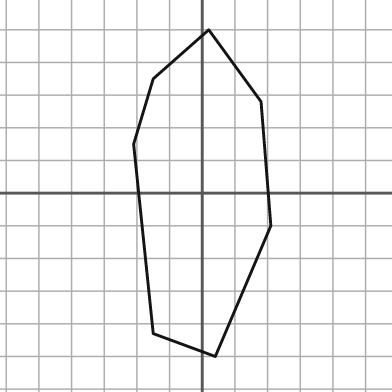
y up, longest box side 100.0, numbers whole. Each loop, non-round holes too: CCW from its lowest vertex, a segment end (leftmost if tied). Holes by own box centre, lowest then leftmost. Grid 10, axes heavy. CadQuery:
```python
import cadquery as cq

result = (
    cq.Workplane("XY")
    .moveTo(4.0, -50.0)
    .lineTo(21.0, -10.0)
    .lineTo(18.0, 28.0)
    .lineTo(2.0, 50.0)
    .lineTo(-15.0, 35.0)
    .lineTo(-21.0, 15.0)
    .lineTo(-15.0, -43.0)
    .close()
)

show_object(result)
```